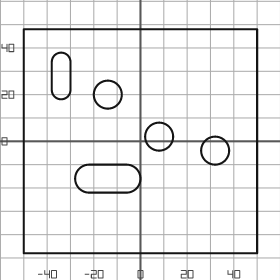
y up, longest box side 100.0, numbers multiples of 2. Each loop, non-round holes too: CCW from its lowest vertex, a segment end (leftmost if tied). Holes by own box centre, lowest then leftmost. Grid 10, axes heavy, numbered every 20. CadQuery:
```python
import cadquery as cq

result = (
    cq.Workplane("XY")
    .moveTo(-50.0, -48.0)
    .lineTo(50.0, -48.0)
    .lineTo(50.0, 48.0)
    .lineTo(-50.0, 48.0)
    .close()
    .moveTo(-22.0, -22.0)
    .lineTo(-6.0, -22.0)
    .threePointArc((0.0, -16.0), (-6.0, -10.0))
    .lineTo(-22.0, -10.0)
    .threePointArc((-28.0, -16.0), (-22.0, -22.0))
    .close()
    .moveTo(32.0, -4.0)
    .circle(6.0)
    .moveTo(8.0, 2.0)
    .circle(6.0)
    .moveTo(-14.0, 20.0)
    .circle(6.0)
    .moveTo(-38.0, 22.0)
    .threePointArc((-34.0, 18.0), (-30.0, 22.0))
    .lineTo(-30.0, 34.0)
    .threePointArc((-34.0, 38.0), (-38.0, 34.0))
    .close()
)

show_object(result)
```